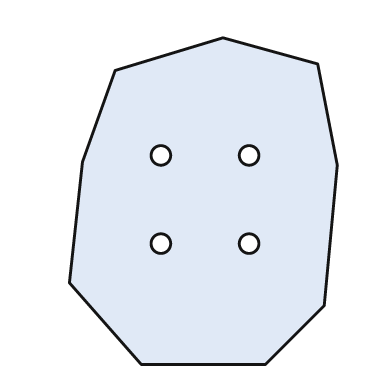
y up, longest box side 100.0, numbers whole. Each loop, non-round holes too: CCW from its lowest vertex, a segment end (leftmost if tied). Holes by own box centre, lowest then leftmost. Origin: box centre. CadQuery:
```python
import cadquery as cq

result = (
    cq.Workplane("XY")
    .moveTo(-19.0, -50.0)
    .lineTo(19.0, -50.0)
    .lineTo(37.0, -32.0)
    .lineTo(41.0, 11.0)
    .lineTo(35.0, 42.0)
    .lineTo(6.0, 50.0)
    .lineTo(-27.0, 40.0)
    .lineTo(-37.0, 12.0)
    .lineTo(-41.0, -25.0)
    .close()
    .moveTo(-13.0, -13.0)
    .circle(3.0)
    .moveTo(14.0, -13.0)
    .circle(3.0)
    .moveTo(-13.0, 14.0)
    .circle(3.0)
    .moveTo(14.0, 14.0)
    .circle(3.0)
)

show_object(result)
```